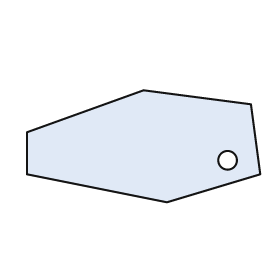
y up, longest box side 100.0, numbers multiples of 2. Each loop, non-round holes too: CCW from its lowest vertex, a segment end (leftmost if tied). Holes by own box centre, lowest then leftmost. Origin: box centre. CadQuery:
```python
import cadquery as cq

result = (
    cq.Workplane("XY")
    .moveTo(10.0, -24.0)
    .lineTo(50.0, -12.0)
    .lineTo(46.0, 18.0)
    .lineTo(0.0, 24.0)
    .lineTo(-50.0, 6.0)
    .lineTo(-50.0, -12.0)
    .close()
    .moveTo(36.0, -6.0)
    .circle(4.0)
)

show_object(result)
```